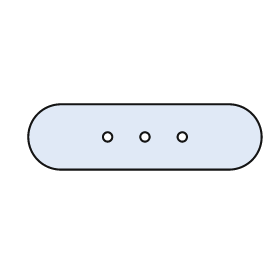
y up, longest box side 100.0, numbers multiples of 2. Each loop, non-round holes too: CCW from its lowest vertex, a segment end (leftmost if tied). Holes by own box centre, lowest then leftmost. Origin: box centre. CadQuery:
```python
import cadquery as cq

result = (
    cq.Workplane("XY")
    .moveTo(-36.0, -14.0)
    .lineTo(36.0, -14.0)
    .threePointArc((50.0, 0.0), (36.0, 14.0))
    .lineTo(-36.0, 14.0)
    .threePointArc((-50.0, 0.0), (-36.0, -14.0))
    .close()
    .moveTo(-16.0, 0.0)
    .circle(2.0)
    .moveTo(0.0, 0.0)
    .circle(2.0)
    .moveTo(16.0, 0.0)
    .circle(2.0)
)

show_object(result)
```